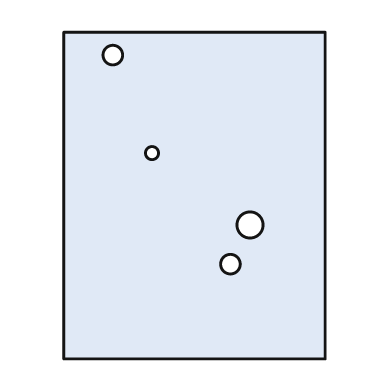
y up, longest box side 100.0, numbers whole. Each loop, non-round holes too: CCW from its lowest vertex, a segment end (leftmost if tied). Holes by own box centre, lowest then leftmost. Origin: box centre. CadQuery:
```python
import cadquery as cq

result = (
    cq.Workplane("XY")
    .moveTo(-40.0, -50.0)
    .lineTo(40.0, -50.0)
    .lineTo(40.0, 50.0)
    .lineTo(-40.0, 50.0)
    .close()
    .moveTo(11.0, -21.0)
    .circle(3.0)
    .moveTo(17.0, -9.0)
    .circle(4.0)
    .moveTo(-13.0, 13.0)
    .circle(2.0)
    .moveTo(-25.0, 43.0)
    .circle(3.0)
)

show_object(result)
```